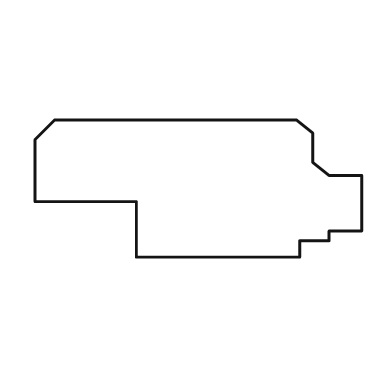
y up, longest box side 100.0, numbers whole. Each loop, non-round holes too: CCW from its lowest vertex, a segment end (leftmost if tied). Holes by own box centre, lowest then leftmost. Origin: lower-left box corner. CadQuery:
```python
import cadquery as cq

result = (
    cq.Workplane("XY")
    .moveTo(31.0, 0.0)
    .lineTo(81.0, 0.0)
    .lineTo(81.0, 5.0)
    .lineTo(90.0, 5.0)
    .lineTo(90.0, 8.0)
    .lineTo(100.0, 8.0)
    .lineTo(100.0, 25.0)
    .lineTo(90.0, 25.0)
    .lineTo(85.0, 29.0)
    .lineTo(85.0, 38.0)
    .lineTo(80.0, 42.0)
    .lineTo(6.0, 42.0)
    .lineTo(0.0, 36.0)
    .lineTo(0.0, 17.0)
    .lineTo(31.0, 17.0)
    .close()
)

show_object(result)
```